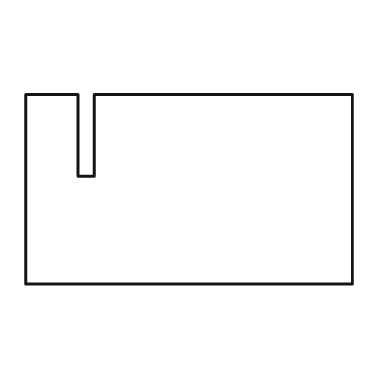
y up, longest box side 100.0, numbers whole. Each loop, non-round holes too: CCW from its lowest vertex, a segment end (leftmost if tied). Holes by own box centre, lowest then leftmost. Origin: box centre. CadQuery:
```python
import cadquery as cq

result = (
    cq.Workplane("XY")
    .moveTo(-50.0, -29.0)
    .lineTo(50.0, -29.0)
    .lineTo(50.0, 29.0)
    .lineTo(-29.0, 29.0)
    .lineTo(-29.0, 4.0)
    .lineTo(-34.0, 4.0)
    .lineTo(-34.0, 29.0)
    .lineTo(-50.0, 29.0)
    .close()
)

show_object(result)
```